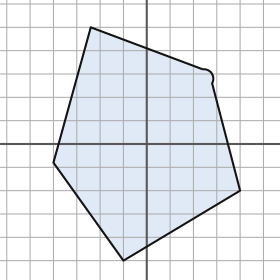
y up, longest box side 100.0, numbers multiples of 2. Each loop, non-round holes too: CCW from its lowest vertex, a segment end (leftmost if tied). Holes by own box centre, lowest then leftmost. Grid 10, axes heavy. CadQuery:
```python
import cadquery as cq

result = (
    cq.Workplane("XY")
    .moveTo(-10.0, -50.0)
    .lineTo(40.0, -20.0)
    .lineTo(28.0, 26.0)
    .threePointArc((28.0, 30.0), (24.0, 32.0))
    .lineTo(-24.0, 50.0)
    .lineTo(-40.0, -8.0)
    .close()
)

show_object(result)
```